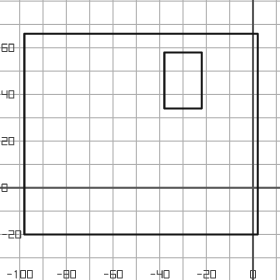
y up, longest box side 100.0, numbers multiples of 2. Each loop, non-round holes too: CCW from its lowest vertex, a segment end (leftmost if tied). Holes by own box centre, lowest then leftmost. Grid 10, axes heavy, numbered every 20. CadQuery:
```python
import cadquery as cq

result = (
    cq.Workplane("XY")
    .moveTo(-98.0, -20.0)
    .lineTo(2.0, -20.0)
    .lineTo(2.0, 66.0)
    .lineTo(-98.0, 66.0)
    .close()
    .moveTo(-38.0, 34.0)
    .lineTo(-22.0, 34.0)
    .lineTo(-22.0, 58.0)
    .lineTo(-38.0, 58.0)
    .close()
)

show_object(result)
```